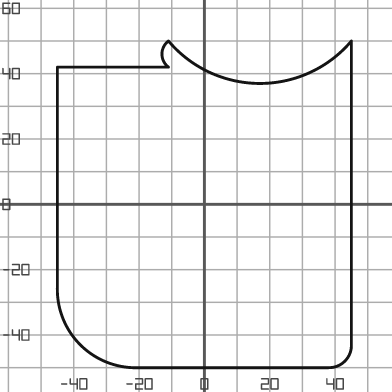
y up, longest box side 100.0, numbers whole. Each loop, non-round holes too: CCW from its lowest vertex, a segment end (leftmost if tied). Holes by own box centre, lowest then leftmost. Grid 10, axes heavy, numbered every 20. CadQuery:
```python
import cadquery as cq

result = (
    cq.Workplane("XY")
    .moveTo(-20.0, -50.0)
    .lineTo(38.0, -50.0)
    .threePointArc((43.0, -48.0), (45.0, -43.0))
    .lineTo(45.0, 50.0)
    .threePointArc((17.0, 37.0), (-11.0, 50.0))
    .threePointArc((-13.0, 46.0), (-11.0, 42.0))
    .lineTo(-45.0, 42.0)
    .lineTo(-45.0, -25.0)
    .threePointArc((-38.0, -43.0), (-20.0, -50.0))
    .close()
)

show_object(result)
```